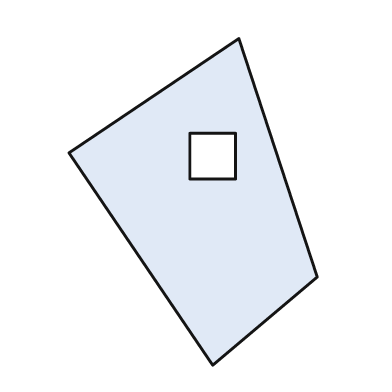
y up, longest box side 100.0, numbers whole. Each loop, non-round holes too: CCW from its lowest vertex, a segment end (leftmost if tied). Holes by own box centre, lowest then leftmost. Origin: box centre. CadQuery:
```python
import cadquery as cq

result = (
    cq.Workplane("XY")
    .moveTo(6.0, -50.0)
    .lineTo(38.0, -23.0)
    .lineTo(14.0, 50.0)
    .lineTo(-38.0, 15.0)
    .close()
    .moveTo(-1.0, 7.0)
    .lineTo(13.0, 7.0)
    .lineTo(13.0, 21.0)
    .lineTo(-1.0, 21.0)
    .close()
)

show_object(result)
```